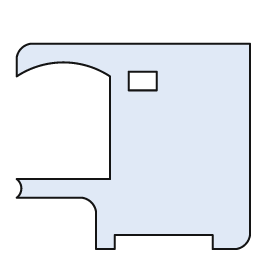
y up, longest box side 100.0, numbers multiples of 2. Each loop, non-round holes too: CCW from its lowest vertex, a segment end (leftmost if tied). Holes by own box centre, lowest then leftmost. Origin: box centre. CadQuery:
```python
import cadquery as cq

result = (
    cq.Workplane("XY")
    .moveTo(-16.0, -44.0)
    .lineTo(-8.0, -44.0)
    .lineTo(-8.0, -38.0)
    .lineTo(34.0, -38.0)
    .lineTo(34.0, -44.0)
    .lineTo(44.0, -44.0)
    .threePointArc((48.0, -42.0), (50.0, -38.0))
    .lineTo(50.0, 44.0)
    .lineTo(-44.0, 44.0)
    .threePointArc((-48.0, 42.0), (-50.0, 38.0))
    .lineTo(-50.0, 30.0)
    .threePointArc((-30.0, 36.0), (-10.0, 30.0))
    .lineTo(-10.0, -14.0)
    .lineTo(-50.0, -14.0)
    .threePointArc((-48.0, -18.0), (-50.0, -22.0))
    .lineTo(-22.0, -22.0)
    .threePointArc((-18.0, -24.0), (-16.0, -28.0))
    .close()
    .moveTo(-2.0, 24.0)
    .lineTo(10.0, 24.0)
    .lineTo(10.0, 32.0)
    .lineTo(-2.0, 32.0)
    .close()
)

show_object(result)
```